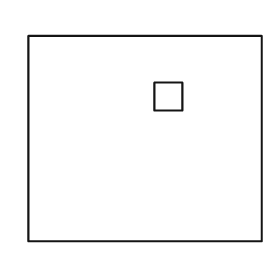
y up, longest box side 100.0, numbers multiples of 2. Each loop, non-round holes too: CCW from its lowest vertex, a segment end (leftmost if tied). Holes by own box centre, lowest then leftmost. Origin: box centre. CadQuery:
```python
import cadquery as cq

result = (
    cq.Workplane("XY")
    .moveTo(-50.0, -44.0)
    .lineTo(50.0, -44.0)
    .lineTo(50.0, 44.0)
    .lineTo(-50.0, 44.0)
    .close()
    .moveTo(4.0, 12.0)
    .lineTo(16.0, 12.0)
    .lineTo(16.0, 24.0)
    .lineTo(4.0, 24.0)
    .close()
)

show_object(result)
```